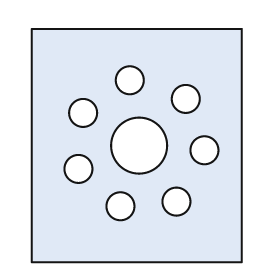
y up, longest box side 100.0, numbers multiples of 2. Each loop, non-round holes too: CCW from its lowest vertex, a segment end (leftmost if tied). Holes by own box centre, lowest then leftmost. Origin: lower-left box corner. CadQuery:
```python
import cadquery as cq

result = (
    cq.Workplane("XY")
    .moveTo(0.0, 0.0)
    .lineTo(90.0, 0.0)
    .lineTo(90.0, 100.0)
    .lineTo(0.0, 100.0)
    .close()
    .moveTo(38.0, 24.0)
    .circle(6.0)
    .moveTo(62.0, 26.0)
    .circle(6.0)
    .moveTo(20.0, 40.0)
    .circle(6.0)
    .moveTo(74.0, 48.0)
    .circle(6.0)
    .moveTo(46.0, 50.0)
    .circle(12.0)
    .moveTo(22.0, 64.0)
    .circle(6.0)
    .moveTo(66.0, 70.0)
    .circle(6.0)
    .moveTo(42.0, 78.0)
    .circle(6.0)
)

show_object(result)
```